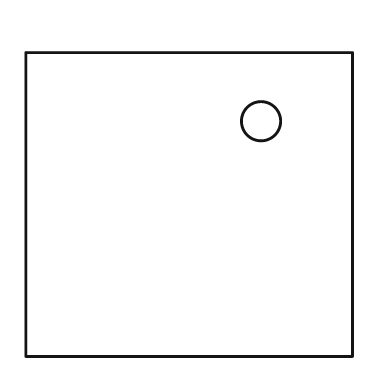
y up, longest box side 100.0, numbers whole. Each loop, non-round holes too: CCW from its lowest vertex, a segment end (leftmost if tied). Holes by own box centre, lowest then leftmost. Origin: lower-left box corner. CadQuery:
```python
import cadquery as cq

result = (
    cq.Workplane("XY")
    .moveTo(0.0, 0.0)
    .lineTo(100.0, 0.0)
    .lineTo(100.0, 93.0)
    .lineTo(0.0, 93.0)
    .close()
    .moveTo(72.0, 72.0)
    .circle(6.0)
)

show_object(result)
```